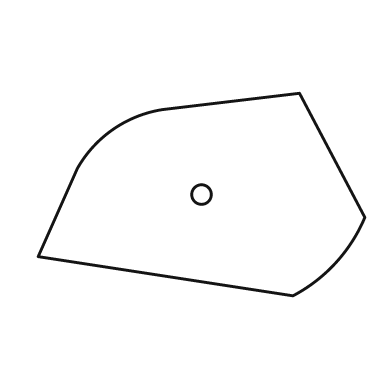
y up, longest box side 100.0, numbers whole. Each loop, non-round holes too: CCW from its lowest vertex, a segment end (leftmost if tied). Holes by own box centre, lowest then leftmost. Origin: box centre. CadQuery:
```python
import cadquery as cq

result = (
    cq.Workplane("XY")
    .moveTo(28.0, -31.0)
    .threePointArc((41.0, -21.0), (50.0, -7.0))
    .lineTo(30.0, 31.0)
    .lineTo(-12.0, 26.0)
    .threePointArc((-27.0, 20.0), (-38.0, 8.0))
    .lineTo(-50.0, -19.0)
    .close()
    .moveTo(0.0, 0.0)
    .circle(3.0)
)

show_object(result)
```